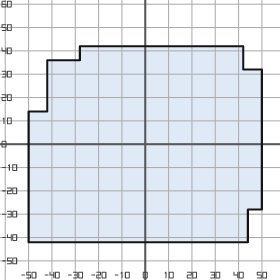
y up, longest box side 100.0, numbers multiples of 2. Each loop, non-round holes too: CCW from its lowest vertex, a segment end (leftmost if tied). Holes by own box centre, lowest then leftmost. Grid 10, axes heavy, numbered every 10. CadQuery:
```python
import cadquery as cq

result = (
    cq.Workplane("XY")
    .moveTo(-50.0, -42.0)
    .lineTo(44.0, -42.0)
    .lineTo(44.0, -28.0)
    .lineTo(50.0, -28.0)
    .lineTo(50.0, 32.0)
    .lineTo(42.0, 32.0)
    .lineTo(42.0, 42.0)
    .lineTo(-28.0, 42.0)
    .lineTo(-28.0, 36.0)
    .lineTo(-42.0, 36.0)
    .lineTo(-42.0, 14.0)
    .lineTo(-50.0, 14.0)
    .close()
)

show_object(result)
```